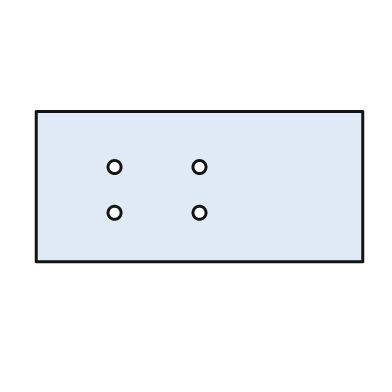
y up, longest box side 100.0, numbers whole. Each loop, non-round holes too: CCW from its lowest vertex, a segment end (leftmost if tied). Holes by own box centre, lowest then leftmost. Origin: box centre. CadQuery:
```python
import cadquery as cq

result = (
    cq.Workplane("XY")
    .moveTo(-50.0, -23.0)
    .lineTo(50.0, -23.0)
    .lineTo(50.0, 23.0)
    .lineTo(-50.0, 23.0)
    .close()
    .moveTo(-26.0, -8.0)
    .circle(2.0)
    .moveTo(0.0, -8.0)
    .circle(2.0)
    .moveTo(-26.0, 6.0)
    .circle(2.0)
    .moveTo(0.0, 6.0)
    .circle(2.0)
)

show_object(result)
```